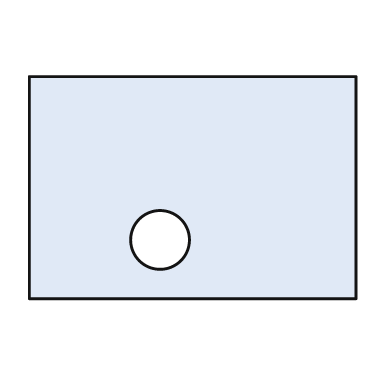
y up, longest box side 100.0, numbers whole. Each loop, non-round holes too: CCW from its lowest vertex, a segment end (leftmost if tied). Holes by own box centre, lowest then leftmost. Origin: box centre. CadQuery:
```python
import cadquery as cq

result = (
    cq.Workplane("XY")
    .moveTo(-50.0, -34.0)
    .lineTo(50.0, -34.0)
    .lineTo(50.0, 34.0)
    .lineTo(-50.0, 34.0)
    .close()
    .moveTo(-10.0, -16.0)
    .circle(9.0)
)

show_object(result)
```